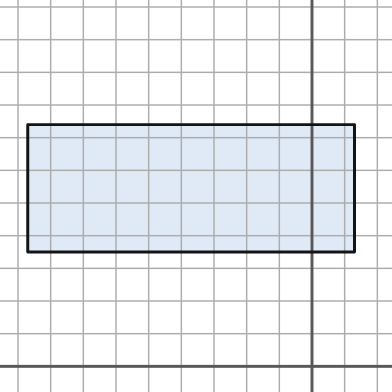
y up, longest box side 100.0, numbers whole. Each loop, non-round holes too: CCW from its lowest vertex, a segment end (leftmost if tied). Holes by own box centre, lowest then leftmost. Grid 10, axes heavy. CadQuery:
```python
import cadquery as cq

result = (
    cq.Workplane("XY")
    .moveTo(-87.0, 35.0)
    .lineTo(13.0, 35.0)
    .lineTo(13.0, 74.0)
    .lineTo(-87.0, 74.0)
    .close()
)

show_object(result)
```